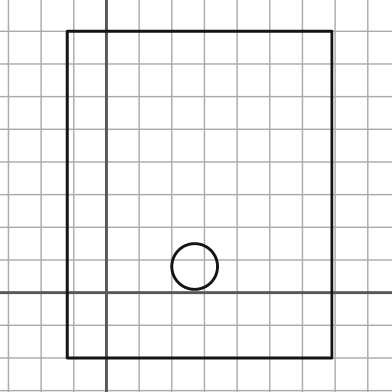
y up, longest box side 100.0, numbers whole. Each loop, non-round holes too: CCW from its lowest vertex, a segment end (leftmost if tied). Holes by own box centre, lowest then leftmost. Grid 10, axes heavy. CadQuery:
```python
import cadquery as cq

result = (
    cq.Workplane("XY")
    .moveTo(-12.0, -20.0)
    .lineTo(69.0, -20.0)
    .lineTo(69.0, 80.0)
    .lineTo(-12.0, 80.0)
    .close()
    .moveTo(27.0, 8.0)
    .circle(7.0)
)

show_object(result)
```